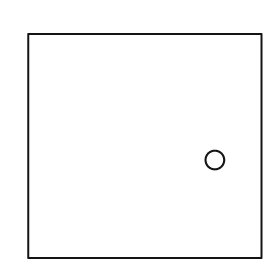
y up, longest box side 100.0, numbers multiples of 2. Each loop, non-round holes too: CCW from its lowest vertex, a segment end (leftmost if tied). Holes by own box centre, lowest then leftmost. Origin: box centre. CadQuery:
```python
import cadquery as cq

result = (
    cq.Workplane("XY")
    .moveTo(-50.0, -48.0)
    .lineTo(50.0, -48.0)
    .lineTo(50.0, 48.0)
    .lineTo(-50.0, 48.0)
    .close()
    .moveTo(30.0, -6.0)
    .circle(4.0)
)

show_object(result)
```